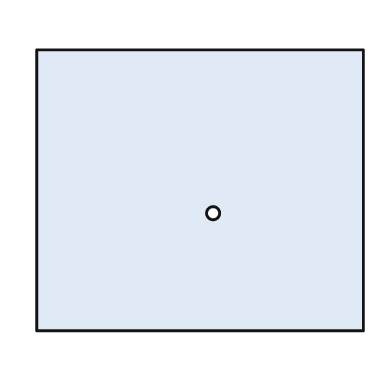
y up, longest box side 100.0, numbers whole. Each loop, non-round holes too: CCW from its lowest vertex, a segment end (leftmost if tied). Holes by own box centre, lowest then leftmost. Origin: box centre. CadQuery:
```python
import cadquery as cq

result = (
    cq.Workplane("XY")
    .moveTo(-50.0, -43.0)
    .lineTo(50.0, -43.0)
    .lineTo(50.0, 43.0)
    .lineTo(-50.0, 43.0)
    .close()
    .moveTo(4.0, -7.0)
    .circle(2.0)
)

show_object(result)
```